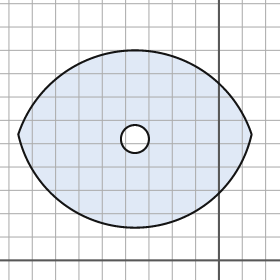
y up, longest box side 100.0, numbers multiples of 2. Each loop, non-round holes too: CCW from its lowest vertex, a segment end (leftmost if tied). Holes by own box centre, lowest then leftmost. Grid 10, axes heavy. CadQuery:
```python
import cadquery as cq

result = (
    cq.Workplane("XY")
    .moveTo(-86.0, 54.0)
    .threePointArc((-36.0, 14.0), (14.0, 54.0))
    .threePointArc((-36.0, 90.0), (-86.0, 54.0))
    .close()
    .moveTo(-36.0, 52.0)
    .circle(6.0)
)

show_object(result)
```